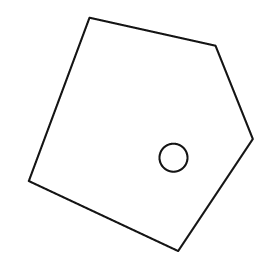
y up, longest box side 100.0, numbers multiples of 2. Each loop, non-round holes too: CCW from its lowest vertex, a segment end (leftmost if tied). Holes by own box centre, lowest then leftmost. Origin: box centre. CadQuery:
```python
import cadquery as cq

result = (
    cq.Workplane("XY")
    .moveTo(16.0, -50.0)
    .lineTo(48.0, -2.0)
    .lineTo(32.0, 38.0)
    .lineTo(-22.0, 50.0)
    .lineTo(-48.0, -20.0)
    .close()
    .moveTo(14.0, -10.0)
    .circle(6.0)
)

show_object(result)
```